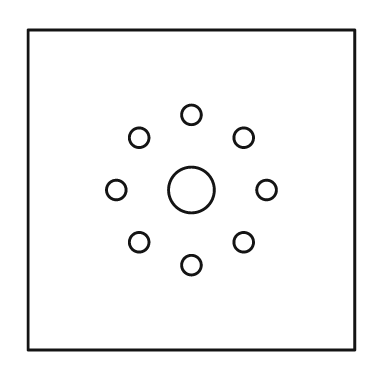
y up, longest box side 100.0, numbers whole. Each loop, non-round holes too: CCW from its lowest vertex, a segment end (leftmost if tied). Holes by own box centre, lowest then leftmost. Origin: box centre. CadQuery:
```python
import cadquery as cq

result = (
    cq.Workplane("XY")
    .moveTo(-50.0, -49.0)
    .lineTo(50.0, -49.0)
    .lineTo(50.0, 49.0)
    .lineTo(-50.0, 49.0)
    .close()
    .moveTo(0.0, -23.0)
    .circle(3.0)
    .moveTo(-16.0, -16.0)
    .circle(3.0)
    .moveTo(16.0, -16.0)
    .circle(3.0)
    .moveTo(-23.0, 0.0)
    .circle(3.0)
    .moveTo(0.0, 0.0)
    .circle(7.0)
    .moveTo(23.0, 0.0)
    .circle(3.0)
    .moveTo(-16.0, 16.0)
    .circle(3.0)
    .moveTo(16.0, 16.0)
    .circle(3.0)
    .moveTo(0.0, 23.0)
    .circle(3.0)
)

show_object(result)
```